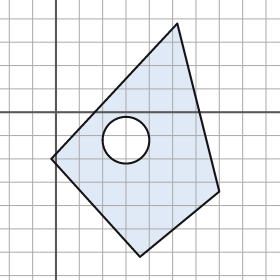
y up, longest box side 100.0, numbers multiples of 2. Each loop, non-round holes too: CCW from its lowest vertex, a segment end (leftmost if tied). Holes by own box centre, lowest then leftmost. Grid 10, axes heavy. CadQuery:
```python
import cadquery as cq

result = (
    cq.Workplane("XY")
    .moveTo(36.0, -62.0)
    .lineTo(70.0, -34.0)
    .lineTo(52.0, 38.0)
    .lineTo(-2.0, -20.0)
    .close()
    .moveTo(30.0, -12.0)
    .circle(10.0)
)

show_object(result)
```